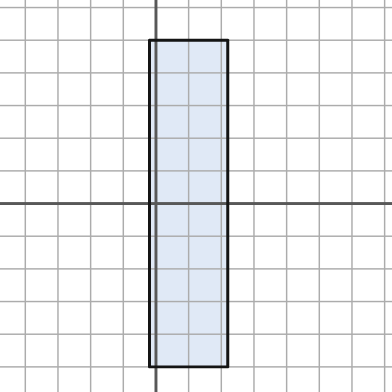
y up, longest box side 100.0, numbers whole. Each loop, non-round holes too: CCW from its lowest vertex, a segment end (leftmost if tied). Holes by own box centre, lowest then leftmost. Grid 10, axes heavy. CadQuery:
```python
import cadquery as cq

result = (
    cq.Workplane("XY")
    .moveTo(-2.0, -50.0)
    .lineTo(22.0, -50.0)
    .lineTo(22.0, 50.0)
    .lineTo(-2.0, 50.0)
    .close()
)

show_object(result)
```